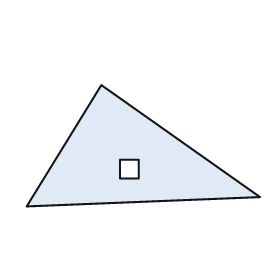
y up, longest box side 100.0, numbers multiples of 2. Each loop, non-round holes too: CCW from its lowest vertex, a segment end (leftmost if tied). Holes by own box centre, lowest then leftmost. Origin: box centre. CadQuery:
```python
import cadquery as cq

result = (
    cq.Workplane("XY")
    .moveTo(-50.0, -26.0)
    .lineTo(50.0, -22.0)
    .lineTo(-18.0, 26.0)
    .close()
    .moveTo(-10.0, -14.0)
    .lineTo(-2.0, -14.0)
    .lineTo(-2.0, -6.0)
    .lineTo(-10.0, -6.0)
    .close()
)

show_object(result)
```